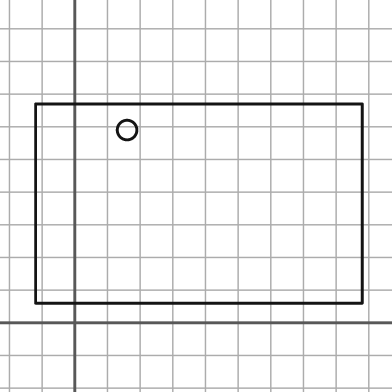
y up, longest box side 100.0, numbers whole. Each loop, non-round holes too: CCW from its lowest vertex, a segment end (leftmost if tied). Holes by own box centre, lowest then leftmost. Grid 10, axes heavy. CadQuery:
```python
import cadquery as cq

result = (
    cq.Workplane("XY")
    .moveTo(-12.0, 6.0)
    .lineTo(88.0, 6.0)
    .lineTo(88.0, 67.0)
    .lineTo(-12.0, 67.0)
    .close()
    .moveTo(16.0, 59.0)
    .circle(3.0)
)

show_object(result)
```